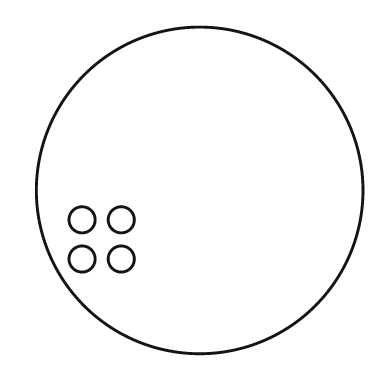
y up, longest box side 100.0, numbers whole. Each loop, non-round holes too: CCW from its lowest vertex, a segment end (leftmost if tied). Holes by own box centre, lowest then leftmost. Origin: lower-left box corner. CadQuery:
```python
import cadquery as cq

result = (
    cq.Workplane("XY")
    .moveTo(50.0, 50.0)
    .circle(50.0)
    .moveTo(14.0, 29.0)
    .circle(4.0)
    .moveTo(26.0, 29.0)
    .circle(4.0)
    .moveTo(14.0, 41.0)
    .circle(4.0)
    .moveTo(26.0, 41.0)
    .circle(4.0)
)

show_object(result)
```